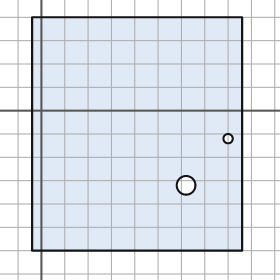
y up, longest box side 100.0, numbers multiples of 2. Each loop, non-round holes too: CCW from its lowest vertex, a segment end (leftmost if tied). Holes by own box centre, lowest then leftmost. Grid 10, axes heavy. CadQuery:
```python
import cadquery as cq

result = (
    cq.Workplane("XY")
    .moveTo(-4.0, -60.0)
    .lineTo(86.0, -60.0)
    .lineTo(86.0, 40.0)
    .lineTo(-4.0, 40.0)
    .close()
    .moveTo(62.0, -32.0)
    .circle(4.0)
    .moveTo(80.0, -12.0)
    .circle(2.0)
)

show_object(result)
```